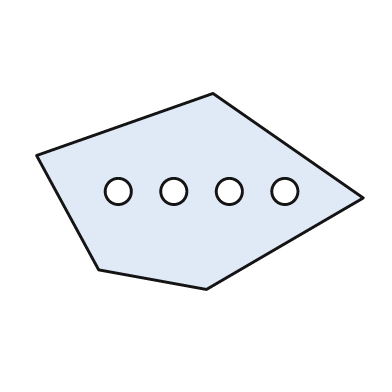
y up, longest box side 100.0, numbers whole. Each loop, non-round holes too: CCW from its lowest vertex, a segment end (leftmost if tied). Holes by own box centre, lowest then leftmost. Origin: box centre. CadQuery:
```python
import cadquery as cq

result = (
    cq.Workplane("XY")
    .moveTo(2.0, -30.0)
    .lineTo(50.0, -2.0)
    .lineTo(4.0, 30.0)
    .lineTo(-50.0, 11.0)
    .lineTo(-31.0, -24.0)
    .close()
    .moveTo(-25.0, 0.0)
    .circle(4.0)
    .moveTo(-8.0, 0.0)
    .circle(4.0)
    .moveTo(9.0, 0.0)
    .circle(4.0)
    .moveTo(26.0, 0.0)
    .circle(4.0)
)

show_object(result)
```